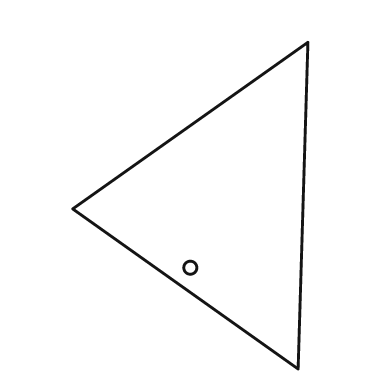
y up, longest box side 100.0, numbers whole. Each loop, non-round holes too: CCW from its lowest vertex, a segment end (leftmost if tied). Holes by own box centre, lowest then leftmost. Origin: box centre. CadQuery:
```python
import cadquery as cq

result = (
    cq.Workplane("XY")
    .moveTo(33.0, -50.0)
    .lineTo(36.0, 50.0)
    .lineTo(-36.0, -1.0)
    .close()
    .moveTo(0.0, -19.0)
    .circle(2.0)
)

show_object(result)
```